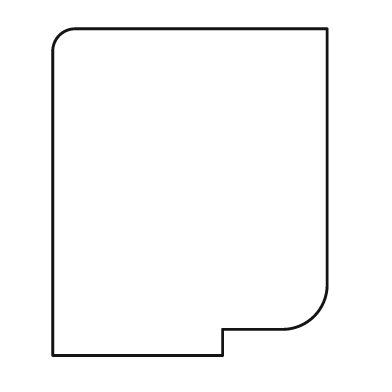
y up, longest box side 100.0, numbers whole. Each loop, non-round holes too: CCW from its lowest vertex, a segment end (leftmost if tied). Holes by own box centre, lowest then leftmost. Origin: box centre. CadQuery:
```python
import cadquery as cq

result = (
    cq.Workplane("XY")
    .moveTo(-42.0, -50.0)
    .lineTo(10.0, -50.0)
    .lineTo(10.0, -42.0)
    .lineTo(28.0, -42.0)
    .threePointArc((38.0, -38.0), (42.0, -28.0))
    .lineTo(42.0, 50.0)
    .lineTo(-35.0, 50.0)
    .threePointArc((-40.0, 48.0), (-42.0, 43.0))
    .close()
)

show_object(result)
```